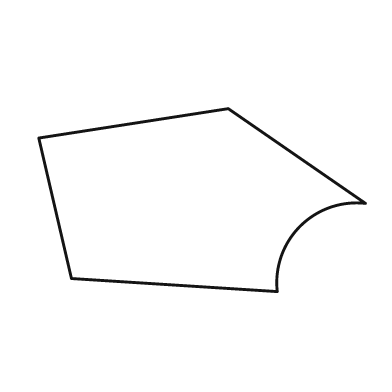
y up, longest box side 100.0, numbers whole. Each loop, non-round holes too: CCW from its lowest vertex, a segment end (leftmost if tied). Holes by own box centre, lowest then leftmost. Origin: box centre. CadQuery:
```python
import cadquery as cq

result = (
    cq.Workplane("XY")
    .moveTo(23.0, -28.0)
    .threePointArc((30.0, -8.0), (50.0, -1.0))
    .lineTo(8.0, 28.0)
    .lineTo(-50.0, 19.0)
    .lineTo(-40.0, -24.0)
    .close()
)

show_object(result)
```